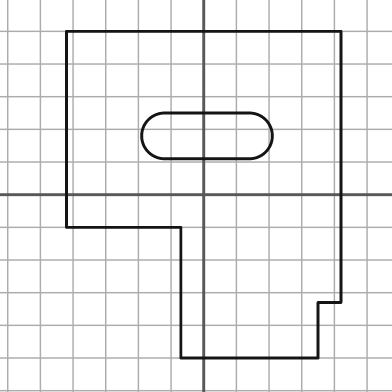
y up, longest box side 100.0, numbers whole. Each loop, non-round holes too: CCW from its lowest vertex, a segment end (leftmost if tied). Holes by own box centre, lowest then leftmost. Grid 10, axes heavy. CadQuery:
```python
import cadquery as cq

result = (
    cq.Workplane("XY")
    .moveTo(-7.0, -50.0)
    .lineTo(35.0, -50.0)
    .lineTo(35.0, -33.0)
    .lineTo(42.0, -33.0)
    .lineTo(42.0, 50.0)
    .lineTo(-42.0, 50.0)
    .lineTo(-42.0, -10.0)
    .lineTo(-7.0, -10.0)
    .close()
    .moveTo(-12.0, 11.0)
    .lineTo(14.0, 11.0)
    .threePointArc((21.0, 18.0), (14.0, 25.0))
    .lineTo(-12.0, 25.0)
    .threePointArc((-19.0, 18.0), (-12.0, 11.0))
    .close()
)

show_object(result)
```